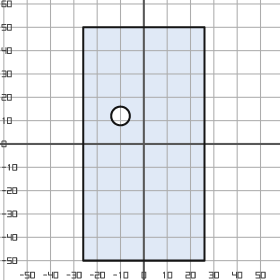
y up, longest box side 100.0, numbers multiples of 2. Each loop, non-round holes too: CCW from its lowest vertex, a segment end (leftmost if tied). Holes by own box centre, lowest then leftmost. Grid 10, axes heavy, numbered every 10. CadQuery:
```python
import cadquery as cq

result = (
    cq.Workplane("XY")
    .moveTo(-26.0, -50.0)
    .lineTo(26.0, -50.0)
    .lineTo(26.0, 50.0)
    .lineTo(-26.0, 50.0)
    .close()
    .moveTo(-10.0, 12.0)
    .circle(4.0)
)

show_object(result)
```